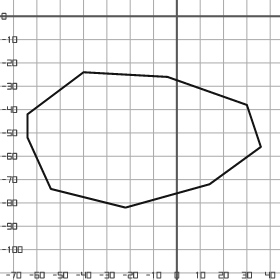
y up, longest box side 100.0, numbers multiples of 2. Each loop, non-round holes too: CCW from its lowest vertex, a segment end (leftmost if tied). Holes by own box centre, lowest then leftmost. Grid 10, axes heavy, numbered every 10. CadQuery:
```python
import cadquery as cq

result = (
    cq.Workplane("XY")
    .moveTo(-22.0, -82.0)
    .lineTo(14.0, -72.0)
    .lineTo(36.0, -56.0)
    .lineTo(30.0, -38.0)
    .lineTo(-4.0, -26.0)
    .lineTo(-40.0, -24.0)
    .lineTo(-64.0, -42.0)
    .lineTo(-64.0, -52.0)
    .lineTo(-54.0, -74.0)
    .close()
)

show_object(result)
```